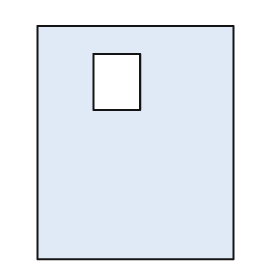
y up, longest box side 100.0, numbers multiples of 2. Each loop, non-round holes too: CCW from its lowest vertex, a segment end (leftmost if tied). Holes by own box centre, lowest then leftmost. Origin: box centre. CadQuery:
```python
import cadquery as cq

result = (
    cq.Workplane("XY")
    .moveTo(-42.0, -50.0)
    .lineTo(42.0, -50.0)
    .lineTo(42.0, 50.0)
    .lineTo(-42.0, 50.0)
    .close()
    .moveTo(-18.0, 14.0)
    .lineTo(2.0, 14.0)
    .lineTo(2.0, 38.0)
    .lineTo(-18.0, 38.0)
    .close()
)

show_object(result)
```